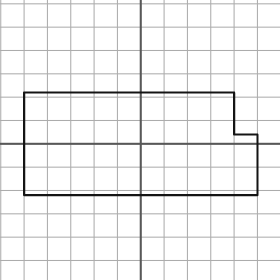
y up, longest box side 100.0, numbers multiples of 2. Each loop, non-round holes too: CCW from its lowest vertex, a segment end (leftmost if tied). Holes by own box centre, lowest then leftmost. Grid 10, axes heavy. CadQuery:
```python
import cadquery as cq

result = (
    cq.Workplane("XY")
    .moveTo(-50.0, -22.0)
    .lineTo(50.0, -22.0)
    .lineTo(50.0, 4.0)
    .lineTo(40.0, 4.0)
    .lineTo(40.0, 22.0)
    .lineTo(-50.0, 22.0)
    .close()
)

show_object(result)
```